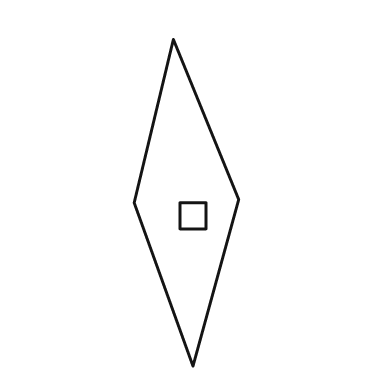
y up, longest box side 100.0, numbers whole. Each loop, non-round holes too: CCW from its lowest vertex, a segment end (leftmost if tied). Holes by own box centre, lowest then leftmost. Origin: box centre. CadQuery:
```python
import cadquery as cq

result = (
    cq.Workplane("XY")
    .moveTo(2.0, -50.0)
    .lineTo(16.0, 1.0)
    .lineTo(-4.0, 50.0)
    .lineTo(-16.0, 0.0)
    .close()
    .moveTo(-2.0, -8.0)
    .lineTo(6.0, -8.0)
    .lineTo(6.0, 0.0)
    .lineTo(-2.0, 0.0)
    .close()
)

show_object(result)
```